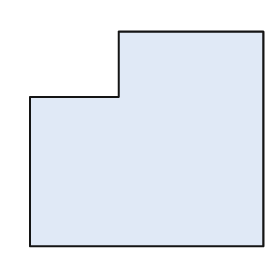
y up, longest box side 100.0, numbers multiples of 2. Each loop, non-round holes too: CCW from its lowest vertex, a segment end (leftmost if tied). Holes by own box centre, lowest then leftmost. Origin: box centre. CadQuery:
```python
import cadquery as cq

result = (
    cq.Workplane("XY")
    .moveTo(-50.0, -46.0)
    .lineTo(50.0, -46.0)
    .lineTo(50.0, 46.0)
    .lineTo(-12.0, 46.0)
    .lineTo(-12.0, 18.0)
    .lineTo(-50.0, 18.0)
    .close()
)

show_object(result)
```